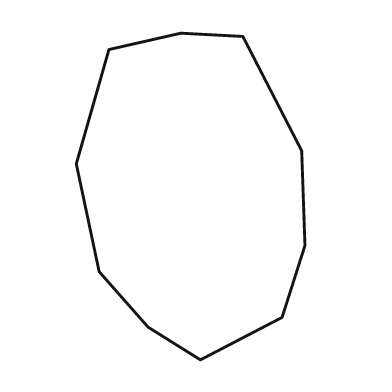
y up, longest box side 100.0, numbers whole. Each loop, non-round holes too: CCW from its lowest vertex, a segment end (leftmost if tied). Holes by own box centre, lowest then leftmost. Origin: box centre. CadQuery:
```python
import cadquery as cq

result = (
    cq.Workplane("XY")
    .moveTo(3.0, -50.0)
    .lineTo(28.0, -37.0)
    .lineTo(35.0, -15.0)
    .lineTo(34.0, 14.0)
    .lineTo(16.0, 49.0)
    .lineTo(-3.0, 50.0)
    .lineTo(-25.0, 45.0)
    .lineTo(-35.0, 10.0)
    .lineTo(-28.0, -23.0)
    .lineTo(-13.0, -40.0)
    .close()
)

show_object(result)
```